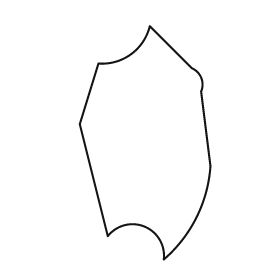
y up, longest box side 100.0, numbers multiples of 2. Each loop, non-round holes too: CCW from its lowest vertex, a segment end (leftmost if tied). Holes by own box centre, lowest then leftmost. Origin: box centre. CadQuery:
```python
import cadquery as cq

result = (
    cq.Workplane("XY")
    .moveTo(8.0, -50.0)
    .threePointArc((22.0, -32.0), (28.0, -10.0))
    .lineTo(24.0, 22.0)
    .threePointArc((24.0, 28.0), (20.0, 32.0))
    .lineTo(2.0, 50.0)
    .threePointArc((-6.0, 38.0), (-20.0, 34.0))
    .lineTo(-28.0, 8.0)
    .lineTo(-16.0, -40.0)
    .threePointArc((0.0, -36.0), (8.0, -50.0))
    .close()
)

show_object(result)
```